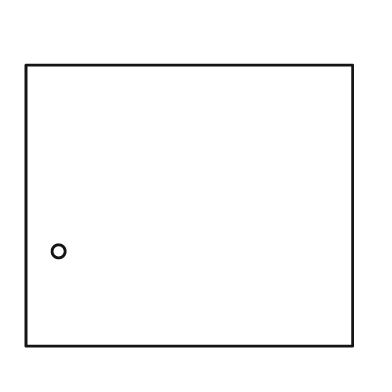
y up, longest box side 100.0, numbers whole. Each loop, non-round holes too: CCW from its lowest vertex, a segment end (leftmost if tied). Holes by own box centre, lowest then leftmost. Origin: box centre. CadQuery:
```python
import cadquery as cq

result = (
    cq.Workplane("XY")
    .moveTo(-50.0, -43.0)
    .lineTo(50.0, -43.0)
    .lineTo(50.0, 43.0)
    .lineTo(-50.0, 43.0)
    .close()
    .moveTo(-40.0, -14.0)
    .circle(2.0)
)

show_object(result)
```